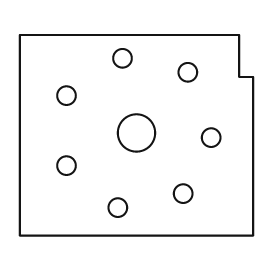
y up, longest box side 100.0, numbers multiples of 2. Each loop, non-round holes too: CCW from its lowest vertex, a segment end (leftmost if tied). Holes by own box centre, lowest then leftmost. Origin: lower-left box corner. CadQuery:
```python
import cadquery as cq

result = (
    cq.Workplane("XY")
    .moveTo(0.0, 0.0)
    .lineTo(100.0, 0.0)
    .lineTo(100.0, 68.0)
    .lineTo(94.0, 68.0)
    .lineTo(94.0, 86.0)
    .lineTo(0.0, 86.0)
    .close()
    .moveTo(42.0, 12.0)
    .circle(4.0)
    .moveTo(70.0, 18.0)
    .circle(4.0)
    .moveTo(20.0, 30.0)
    .circle(4.0)
    .moveTo(82.0, 42.0)
    .circle(4.0)
    .moveTo(50.0, 44.0)
    .circle(8.0)
    .moveTo(20.0, 60.0)
    .circle(4.0)
    .moveTo(72.0, 70.0)
    .circle(4.0)
    .moveTo(44.0, 76.0)
    .circle(4.0)
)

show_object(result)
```